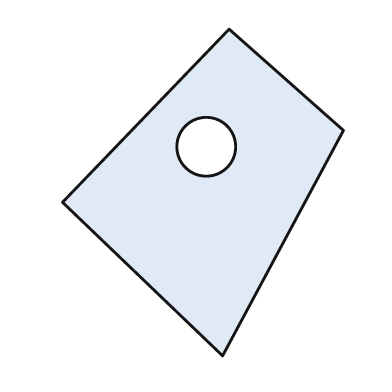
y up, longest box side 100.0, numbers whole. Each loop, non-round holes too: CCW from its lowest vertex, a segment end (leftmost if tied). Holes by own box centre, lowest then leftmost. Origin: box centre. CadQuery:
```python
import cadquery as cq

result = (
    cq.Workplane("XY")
    .moveTo(6.0, -50.0)
    .lineTo(43.0, 19.0)
    .lineTo(8.0, 50.0)
    .lineTo(-43.0, -3.0)
    .close()
    .moveTo(1.0, 14.0)
    .circle(9.0)
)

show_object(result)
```